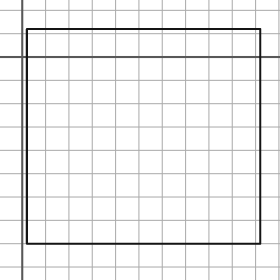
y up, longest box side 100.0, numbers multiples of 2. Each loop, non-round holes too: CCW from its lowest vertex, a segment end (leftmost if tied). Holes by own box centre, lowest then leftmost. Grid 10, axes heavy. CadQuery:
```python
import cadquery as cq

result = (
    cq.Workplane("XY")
    .moveTo(2.0, -80.0)
    .lineTo(102.0, -80.0)
    .lineTo(102.0, 12.0)
    .lineTo(2.0, 12.0)
    .close()
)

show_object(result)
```